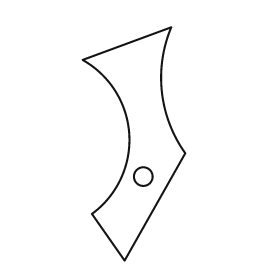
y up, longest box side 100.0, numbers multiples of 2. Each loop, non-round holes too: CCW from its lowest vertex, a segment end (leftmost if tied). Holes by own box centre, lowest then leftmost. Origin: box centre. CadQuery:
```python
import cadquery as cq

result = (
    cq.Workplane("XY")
    .moveTo(-4.0, -50.0)
    .lineTo(22.0, -4.0)
    .threePointArc((12.0, 22.0), (16.0, 50.0))
    .lineTo(-22.0, 36.0)
    .threePointArc((-2.0, 4.0), (-18.0, -30.0))
    .close()
    .moveTo(4.0, -14.0)
    .circle(4.0)
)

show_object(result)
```